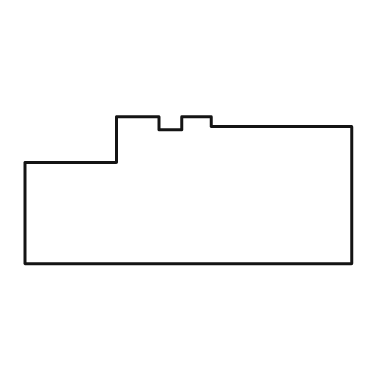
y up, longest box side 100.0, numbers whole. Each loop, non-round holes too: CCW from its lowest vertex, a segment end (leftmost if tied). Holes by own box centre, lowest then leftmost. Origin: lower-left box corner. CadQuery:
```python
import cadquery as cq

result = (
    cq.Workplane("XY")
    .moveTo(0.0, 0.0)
    .lineTo(100.0, 0.0)
    .lineTo(100.0, 42.0)
    .lineTo(57.0, 42.0)
    .lineTo(57.0, 45.0)
    .lineTo(48.0, 45.0)
    .lineTo(48.0, 41.0)
    .lineTo(41.0, 41.0)
    .lineTo(41.0, 45.0)
    .lineTo(28.0, 45.0)
    .lineTo(28.0, 31.0)
    .lineTo(0.0, 31.0)
    .close()
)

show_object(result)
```